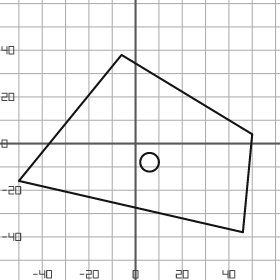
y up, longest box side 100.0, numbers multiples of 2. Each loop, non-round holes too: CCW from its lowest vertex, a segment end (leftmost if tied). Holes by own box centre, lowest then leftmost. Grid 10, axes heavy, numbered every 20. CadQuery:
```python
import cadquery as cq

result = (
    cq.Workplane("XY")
    .moveTo(46.0, -38.0)
    .lineTo(50.0, 4.0)
    .lineTo(-6.0, 38.0)
    .lineTo(-50.0, -16.0)
    .close()
    .moveTo(6.0, -8.0)
    .circle(4.0)
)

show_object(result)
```